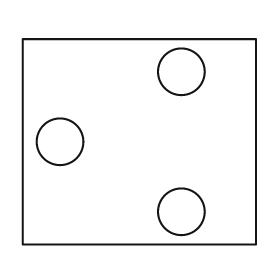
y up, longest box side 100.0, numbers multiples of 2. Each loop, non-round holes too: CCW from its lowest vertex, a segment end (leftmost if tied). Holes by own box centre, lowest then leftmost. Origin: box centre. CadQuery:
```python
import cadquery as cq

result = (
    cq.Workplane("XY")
    .moveTo(-50.0, -44.0)
    .lineTo(50.0, -44.0)
    .lineTo(50.0, 44.0)
    .lineTo(-50.0, 44.0)
    .close()
    .moveTo(18.0, -30.0)
    .circle(10.0)
    .moveTo(-34.0, 0.0)
    .circle(10.0)
    .moveTo(18.0, 30.0)
    .circle(10.0)
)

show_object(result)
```